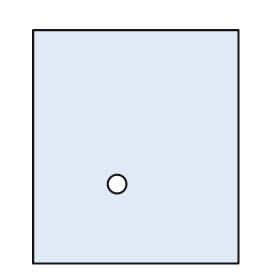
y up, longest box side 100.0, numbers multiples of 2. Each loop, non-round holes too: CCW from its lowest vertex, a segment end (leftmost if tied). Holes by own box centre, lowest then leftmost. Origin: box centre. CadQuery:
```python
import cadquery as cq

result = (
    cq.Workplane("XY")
    .moveTo(-44.0, -50.0)
    .lineTo(44.0, -50.0)
    .lineTo(44.0, 50.0)
    .lineTo(-44.0, 50.0)
    .close()
    .moveTo(-8.0, -16.0)
    .circle(4.0)
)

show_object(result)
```